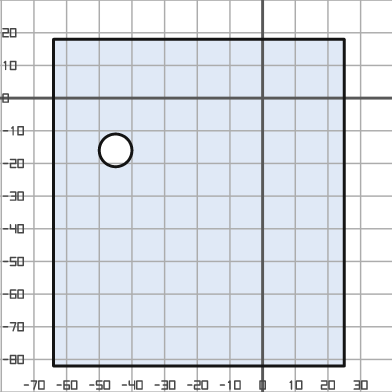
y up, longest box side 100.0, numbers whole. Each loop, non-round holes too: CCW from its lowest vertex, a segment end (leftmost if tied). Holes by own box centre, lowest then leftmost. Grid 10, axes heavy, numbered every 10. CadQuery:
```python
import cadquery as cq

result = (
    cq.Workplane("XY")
    .moveTo(-64.0, -82.0)
    .lineTo(25.0, -82.0)
    .lineTo(25.0, 18.0)
    .lineTo(-64.0, 18.0)
    .close()
    .moveTo(-45.0, -16.0)
    .circle(5.0)
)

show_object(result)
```